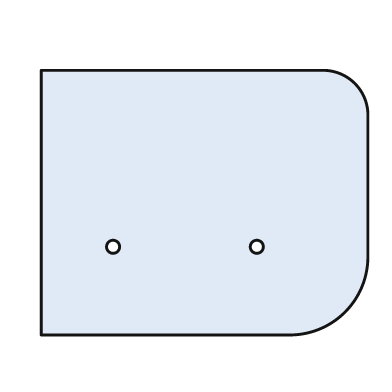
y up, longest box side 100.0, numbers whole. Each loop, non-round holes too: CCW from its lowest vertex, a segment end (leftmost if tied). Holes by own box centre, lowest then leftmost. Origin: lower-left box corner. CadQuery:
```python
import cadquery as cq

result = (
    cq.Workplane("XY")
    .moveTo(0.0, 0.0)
    .lineTo(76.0, 0.0)
    .threePointArc((93.0, 7.0), (100.0, 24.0))
    .lineTo(100.0, 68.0)
    .threePointArc((96.0, 77.0), (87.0, 81.0))
    .lineTo(0.0, 81.0)
    .close()
    .moveTo(22.0, 27.0)
    .circle(2.0)
    .moveTo(66.0, 27.0)
    .circle(2.0)
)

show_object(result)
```